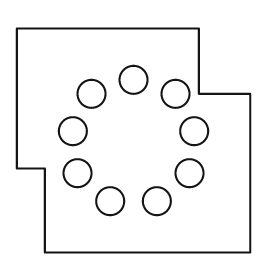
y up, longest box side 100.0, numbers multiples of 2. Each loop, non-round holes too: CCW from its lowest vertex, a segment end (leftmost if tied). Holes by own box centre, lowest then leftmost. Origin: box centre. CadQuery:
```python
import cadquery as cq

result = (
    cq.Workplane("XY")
    .moveTo(-38.0, -48.0)
    .lineTo(50.0, -48.0)
    .lineTo(50.0, 20.0)
    .lineTo(28.0, 20.0)
    .lineTo(28.0, 48.0)
    .lineTo(-50.0, 48.0)
    .lineTo(-50.0, -12.0)
    .lineTo(-38.0, -12.0)
    .close()
    .moveTo(-10.0, -26.0)
    .circle(6.0)
    .moveTo(10.0, -26.0)
    .circle(6.0)
    .moveTo(-24.0, -14.0)
    .circle(6.0)
    .moveTo(24.0, -14.0)
    .circle(6.0)
    .moveTo(-26.0, 4.0)
    .circle(6.0)
    .moveTo(26.0, 4.0)
    .circle(6.0)
    .moveTo(-18.0, 20.0)
    .circle(6.0)
    .moveTo(18.0, 20.0)
    .circle(6.0)
    .moveTo(0.0, 26.0)
    .circle(6.0)
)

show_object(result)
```